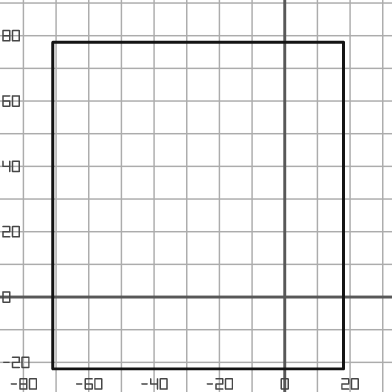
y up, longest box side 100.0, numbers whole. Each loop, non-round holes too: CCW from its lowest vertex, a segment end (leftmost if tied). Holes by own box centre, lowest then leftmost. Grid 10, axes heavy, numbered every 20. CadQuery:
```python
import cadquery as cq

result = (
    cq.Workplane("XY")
    .moveTo(-71.0, -22.0)
    .lineTo(18.0, -22.0)
    .lineTo(18.0, 78.0)
    .lineTo(-71.0, 78.0)
    .close()
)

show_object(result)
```